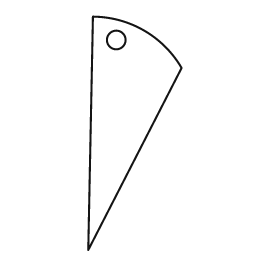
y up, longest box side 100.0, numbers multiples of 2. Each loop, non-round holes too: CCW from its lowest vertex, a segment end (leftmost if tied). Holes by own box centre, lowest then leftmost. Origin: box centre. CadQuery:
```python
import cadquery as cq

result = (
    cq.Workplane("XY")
    .moveTo(-20.0, -50.0)
    .lineTo(20.0, 28.0)
    .threePointArc((4.0, 44.0), (-18.0, 50.0))
    .close()
    .moveTo(-8.0, 40.0)
    .circle(4.0)
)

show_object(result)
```